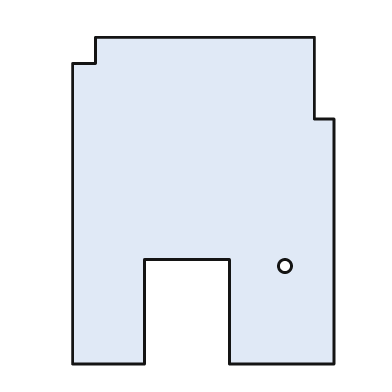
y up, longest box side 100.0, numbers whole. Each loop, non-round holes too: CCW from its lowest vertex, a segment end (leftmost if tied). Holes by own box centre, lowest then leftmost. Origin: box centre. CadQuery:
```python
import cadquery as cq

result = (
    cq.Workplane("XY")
    .moveTo(-40.0, -50.0)
    .lineTo(-18.0, -50.0)
    .lineTo(-18.0, -18.0)
    .lineTo(8.0, -18.0)
    .lineTo(8.0, -50.0)
    .lineTo(40.0, -50.0)
    .lineTo(40.0, 25.0)
    .lineTo(34.0, 25.0)
    .lineTo(34.0, 50.0)
    .lineTo(-33.0, 50.0)
    .lineTo(-33.0, 42.0)
    .lineTo(-40.0, 42.0)
    .close()
    .moveTo(25.0, -20.0)
    .circle(2.0)
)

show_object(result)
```